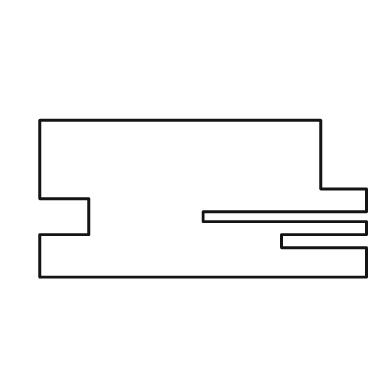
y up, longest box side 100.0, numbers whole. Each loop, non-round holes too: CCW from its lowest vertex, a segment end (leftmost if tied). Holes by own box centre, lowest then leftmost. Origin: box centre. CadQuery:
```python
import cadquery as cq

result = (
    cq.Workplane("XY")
    .moveTo(-50.0, -24.0)
    .lineTo(50.0, -24.0)
    .lineTo(50.0, -15.0)
    .lineTo(24.0, -15.0)
    .lineTo(24.0, -11.0)
    .lineTo(50.0, -11.0)
    .lineTo(50.0, -7.0)
    .lineTo(0.0, -7.0)
    .lineTo(0.0, -4.0)
    .lineTo(50.0, -4.0)
    .lineTo(50.0, 3.0)
    .lineTo(36.0, 3.0)
    .lineTo(36.0, 24.0)
    .lineTo(-50.0, 24.0)
    .lineTo(-50.0, 0.0)
    .lineTo(-35.0, 0.0)
    .lineTo(-35.0, -11.0)
    .lineTo(-50.0, -11.0)
    .close()
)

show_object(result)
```